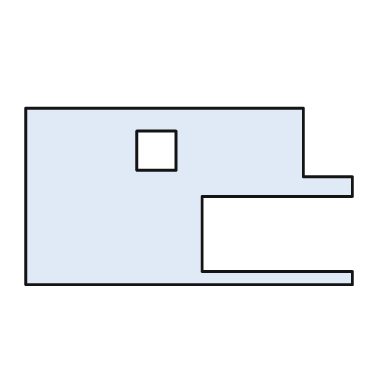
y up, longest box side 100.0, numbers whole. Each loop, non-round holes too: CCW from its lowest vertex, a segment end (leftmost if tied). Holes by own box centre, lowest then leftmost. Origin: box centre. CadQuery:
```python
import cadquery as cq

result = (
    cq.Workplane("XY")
    .moveTo(-50.0, -27.0)
    .lineTo(50.0, -27.0)
    .lineTo(50.0, -23.0)
    .lineTo(4.0, -23.0)
    .lineTo(4.0, 0.0)
    .lineTo(50.0, 0.0)
    .lineTo(50.0, 6.0)
    .lineTo(35.0, 6.0)
    .lineTo(35.0, 27.0)
    .lineTo(-50.0, 27.0)
    .close()
    .moveTo(-16.0, 8.0)
    .lineTo(-4.0, 8.0)
    .lineTo(-4.0, 20.0)
    .lineTo(-16.0, 20.0)
    .close()
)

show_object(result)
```